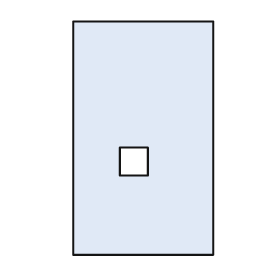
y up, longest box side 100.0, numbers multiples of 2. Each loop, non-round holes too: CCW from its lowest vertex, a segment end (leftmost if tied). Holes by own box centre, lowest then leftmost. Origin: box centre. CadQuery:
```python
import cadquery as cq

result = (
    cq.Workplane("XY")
    .moveTo(-30.0, -50.0)
    .lineTo(30.0, -50.0)
    .lineTo(30.0, 50.0)
    .lineTo(-30.0, 50.0)
    .close()
    .moveTo(-10.0, -16.0)
    .lineTo(2.0, -16.0)
    .lineTo(2.0, -4.0)
    .lineTo(-10.0, -4.0)
    .close()
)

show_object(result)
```